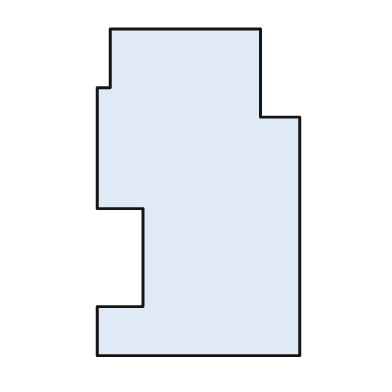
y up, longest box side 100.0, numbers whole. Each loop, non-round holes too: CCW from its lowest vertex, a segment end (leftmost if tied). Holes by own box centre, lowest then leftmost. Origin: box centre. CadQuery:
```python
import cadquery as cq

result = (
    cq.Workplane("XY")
    .moveTo(-31.0, -50.0)
    .lineTo(31.0, -50.0)
    .lineTo(31.0, 23.0)
    .lineTo(19.0, 23.0)
    .lineTo(19.0, 50.0)
    .lineTo(-27.0, 50.0)
    .lineTo(-27.0, 32.0)
    .lineTo(-31.0, 32.0)
    .lineTo(-31.0, -5.0)
    .lineTo(-17.0, -5.0)
    .lineTo(-17.0, -35.0)
    .lineTo(-31.0, -35.0)
    .close()
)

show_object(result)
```